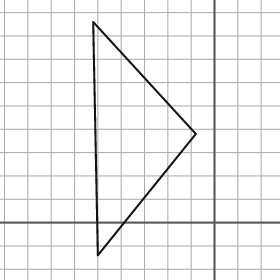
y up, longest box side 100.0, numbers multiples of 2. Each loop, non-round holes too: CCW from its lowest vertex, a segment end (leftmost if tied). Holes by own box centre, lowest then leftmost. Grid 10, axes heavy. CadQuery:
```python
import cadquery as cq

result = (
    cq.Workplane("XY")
    .moveTo(-50.0, -14.0)
    .lineTo(-8.0, 38.0)
    .lineTo(-52.0, 86.0)
    .close()
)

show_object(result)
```